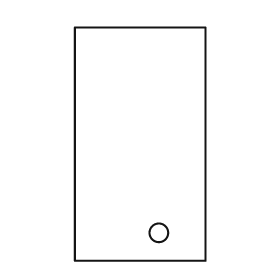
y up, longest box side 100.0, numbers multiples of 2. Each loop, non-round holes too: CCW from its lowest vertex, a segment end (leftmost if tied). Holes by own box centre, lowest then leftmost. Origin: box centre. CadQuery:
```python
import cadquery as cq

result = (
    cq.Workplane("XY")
    .moveTo(-28.0, -50.0)
    .lineTo(28.0, -50.0)
    .lineTo(28.0, 50.0)
    .lineTo(-28.0, 50.0)
    .close()
    .moveTo(8.0, -38.0)
    .circle(4.0)
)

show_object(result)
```